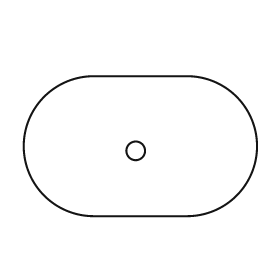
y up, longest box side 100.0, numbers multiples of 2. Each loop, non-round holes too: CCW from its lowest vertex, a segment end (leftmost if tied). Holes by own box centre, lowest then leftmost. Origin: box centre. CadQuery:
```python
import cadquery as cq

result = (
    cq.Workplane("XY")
    .moveTo(-20.0, -30.0)
    .lineTo(20.0, -30.0)
    .threePointArc((50.0, 0.0), (20.0, 30.0))
    .lineTo(-20.0, 30.0)
    .threePointArc((-50.0, 0.0), (-20.0, -30.0))
    .close()
    .moveTo(-2.0, -2.0)
    .circle(4.0)
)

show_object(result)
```